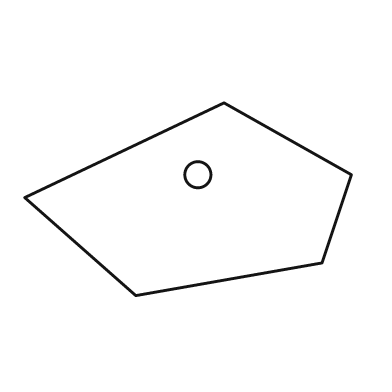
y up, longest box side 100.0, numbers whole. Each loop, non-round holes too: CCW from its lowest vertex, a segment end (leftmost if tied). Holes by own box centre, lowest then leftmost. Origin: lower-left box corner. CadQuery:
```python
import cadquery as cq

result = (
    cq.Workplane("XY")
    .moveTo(34.0, 0.0)
    .lineTo(91.0, 10.0)
    .lineTo(100.0, 37.0)
    .lineTo(61.0, 59.0)
    .lineTo(0.0, 30.0)
    .close()
    .moveTo(53.0, 37.0)
    .circle(4.0)
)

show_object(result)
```